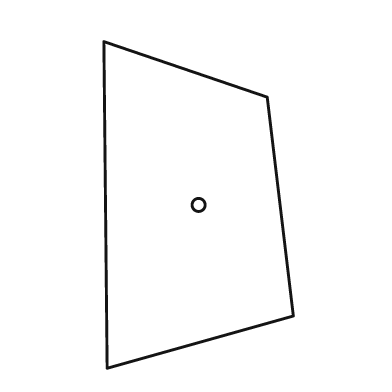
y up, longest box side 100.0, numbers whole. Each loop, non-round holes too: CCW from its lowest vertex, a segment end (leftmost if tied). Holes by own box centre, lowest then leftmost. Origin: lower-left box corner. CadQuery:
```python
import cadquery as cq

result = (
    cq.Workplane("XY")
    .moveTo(1.0, 0.0)
    .lineTo(58.0, 16.0)
    .lineTo(50.0, 83.0)
    .lineTo(0.0, 100.0)
    .close()
    .moveTo(29.0, 50.0)
    .circle(2.0)
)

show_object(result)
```